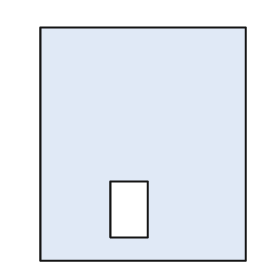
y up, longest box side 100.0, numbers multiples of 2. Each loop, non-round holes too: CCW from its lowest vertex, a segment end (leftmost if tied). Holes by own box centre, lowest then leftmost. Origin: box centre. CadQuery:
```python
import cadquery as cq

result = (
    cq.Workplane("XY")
    .moveTo(-44.0, -50.0)
    .lineTo(44.0, -50.0)
    .lineTo(44.0, 50.0)
    .lineTo(-44.0, 50.0)
    .close()
    .moveTo(-14.0, -40.0)
    .lineTo(2.0, -40.0)
    .lineTo(2.0, -16.0)
    .lineTo(-14.0, -16.0)
    .close()
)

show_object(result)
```